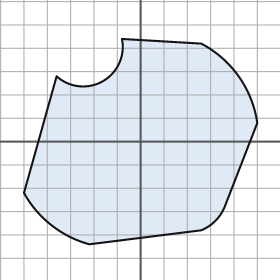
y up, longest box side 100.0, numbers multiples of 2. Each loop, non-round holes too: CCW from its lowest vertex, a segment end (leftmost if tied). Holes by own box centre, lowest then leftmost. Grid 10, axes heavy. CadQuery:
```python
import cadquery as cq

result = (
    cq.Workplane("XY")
    .moveTo(-22.0, -44.0)
    .lineTo(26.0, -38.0)
    .threePointArc((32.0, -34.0), (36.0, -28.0))
    .lineTo(50.0, 8.0)
    .threePointArc((42.0, 28.0), (26.0, 42.0))
    .lineTo(-8.0, 44.0)
    .threePointArc((-16.0, 26.0), (-36.0, 28.0))
    .lineTo(-50.0, -22.0)
    .threePointArc((-38.0, -36.0), (-22.0, -44.0))
    .close()
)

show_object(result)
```